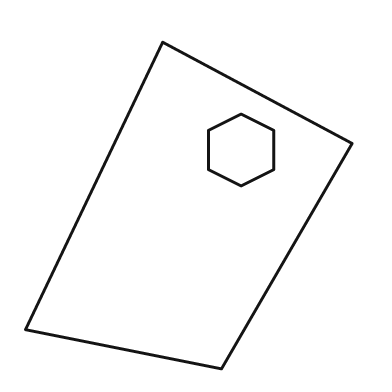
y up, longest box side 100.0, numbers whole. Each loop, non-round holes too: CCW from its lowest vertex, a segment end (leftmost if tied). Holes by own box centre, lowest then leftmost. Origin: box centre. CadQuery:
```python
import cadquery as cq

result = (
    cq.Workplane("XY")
    .moveTo(10.0, -50.0)
    .lineTo(50.0, 19.0)
    .lineTo(-8.0, 50.0)
    .lineTo(-50.0, -38.0)
    .close()
    .moveTo(16.0, 6.0)
    .lineTo(26.0, 11.0)
    .lineTo(26.0, 23.0)
    .lineTo(16.0, 28.0)
    .lineTo(6.0, 23.0)
    .lineTo(6.0, 11.0)
    .close()
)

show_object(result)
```